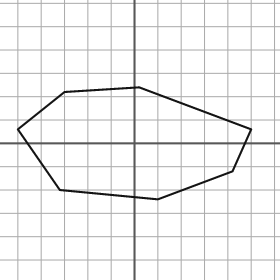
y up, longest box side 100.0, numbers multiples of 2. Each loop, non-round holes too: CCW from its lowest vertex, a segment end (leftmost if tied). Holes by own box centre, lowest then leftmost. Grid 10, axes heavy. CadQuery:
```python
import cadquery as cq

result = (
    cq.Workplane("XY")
    .moveTo(10.0, -24.0)
    .lineTo(42.0, -12.0)
    .lineTo(50.0, 6.0)
    .lineTo(2.0, 24.0)
    .lineTo(-30.0, 22.0)
    .lineTo(-50.0, 6.0)
    .lineTo(-32.0, -20.0)
    .close()
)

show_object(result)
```